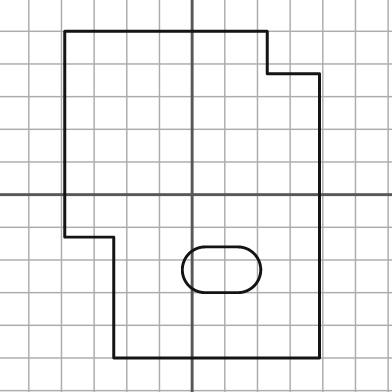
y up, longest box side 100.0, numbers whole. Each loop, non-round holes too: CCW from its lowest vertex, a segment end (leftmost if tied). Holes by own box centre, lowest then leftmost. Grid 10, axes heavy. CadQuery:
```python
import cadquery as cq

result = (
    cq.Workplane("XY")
    .moveTo(-24.0, -50.0)
    .lineTo(39.0, -50.0)
    .lineTo(39.0, 37.0)
    .lineTo(23.0, 37.0)
    .lineTo(23.0, 50.0)
    .lineTo(-39.0, 50.0)
    .lineTo(-39.0, -13.0)
    .lineTo(-24.0, -13.0)
    .close()
    .moveTo(4.0, -30.0)
    .lineTo(14.0, -30.0)
    .threePointArc((21.0, -23.0), (14.0, -16.0))
    .lineTo(4.0, -16.0)
    .threePointArc((-3.0, -23.0), (4.0, -30.0))
    .close()
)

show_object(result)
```